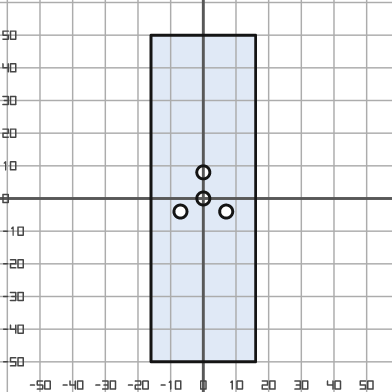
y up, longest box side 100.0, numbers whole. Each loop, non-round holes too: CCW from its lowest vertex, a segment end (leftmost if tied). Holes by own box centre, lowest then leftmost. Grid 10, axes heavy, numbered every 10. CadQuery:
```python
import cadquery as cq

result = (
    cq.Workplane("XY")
    .moveTo(-16.0, -50.0)
    .lineTo(16.0, -50.0)
    .lineTo(16.0, 50.0)
    .lineTo(-16.0, 50.0)
    .close()
    .moveTo(-7.0, -4.0)
    .circle(2.0)
    .moveTo(7.0, -4.0)
    .circle(2.0)
    .moveTo(0.0, 0.0)
    .circle(2.0)
    .moveTo(0.0, 8.0)
    .circle(2.0)
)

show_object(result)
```